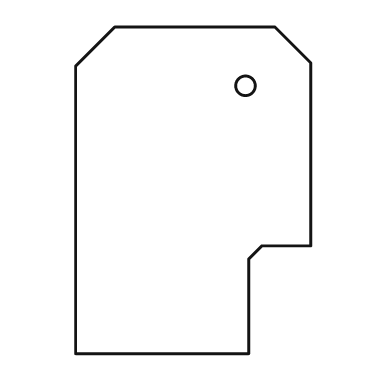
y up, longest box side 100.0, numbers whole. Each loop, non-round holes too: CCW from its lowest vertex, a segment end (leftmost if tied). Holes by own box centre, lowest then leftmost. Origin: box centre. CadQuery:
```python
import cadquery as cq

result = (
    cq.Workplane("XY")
    .moveTo(-36.0, -50.0)
    .lineTo(17.0, -50.0)
    .lineTo(17.0, -21.0)
    .lineTo(21.0, -17.0)
    .lineTo(36.0, -17.0)
    .lineTo(36.0, 39.0)
    .lineTo(25.0, 50.0)
    .lineTo(-24.0, 50.0)
    .lineTo(-36.0, 38.0)
    .close()
    .moveTo(16.0, 32.0)
    .circle(3.0)
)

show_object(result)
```